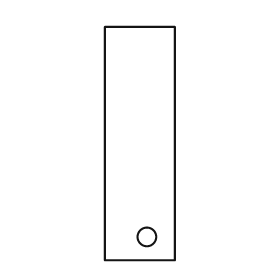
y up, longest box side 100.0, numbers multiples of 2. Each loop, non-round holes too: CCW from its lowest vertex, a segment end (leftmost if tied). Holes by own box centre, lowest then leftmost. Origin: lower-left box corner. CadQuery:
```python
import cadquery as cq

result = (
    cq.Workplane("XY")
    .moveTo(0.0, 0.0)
    .lineTo(30.0, 0.0)
    .lineTo(30.0, 100.0)
    .lineTo(0.0, 100.0)
    .close()
    .moveTo(18.0, 10.0)
    .circle(4.0)
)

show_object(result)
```